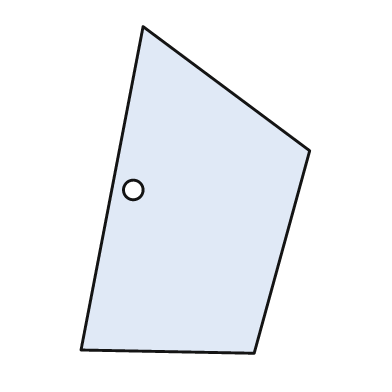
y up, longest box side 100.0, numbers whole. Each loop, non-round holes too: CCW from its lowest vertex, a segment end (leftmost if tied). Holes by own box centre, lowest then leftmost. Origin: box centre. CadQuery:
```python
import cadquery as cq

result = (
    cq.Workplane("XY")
    .moveTo(18.0, -50.0)
    .lineTo(35.0, 12.0)
    .lineTo(-16.0, 50.0)
    .lineTo(-35.0, -49.0)
    .close()
    .moveTo(-19.0, 0.0)
    .circle(3.0)
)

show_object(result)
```